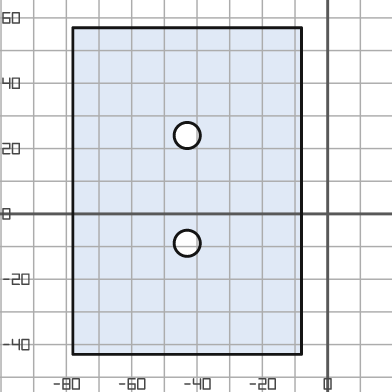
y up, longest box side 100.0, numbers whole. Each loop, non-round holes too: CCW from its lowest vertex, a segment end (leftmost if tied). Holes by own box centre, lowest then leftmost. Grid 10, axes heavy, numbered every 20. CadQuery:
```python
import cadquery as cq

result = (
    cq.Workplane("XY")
    .moveTo(-78.0, -43.0)
    .lineTo(-8.0, -43.0)
    .lineTo(-8.0, 57.0)
    .lineTo(-78.0, 57.0)
    .close()
    .moveTo(-43.0, -9.0)
    .circle(4.0)
    .moveTo(-43.0, 24.0)
    .circle(4.0)
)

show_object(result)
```